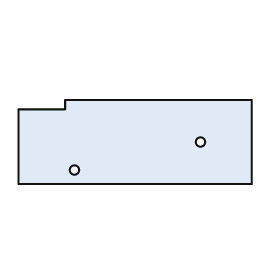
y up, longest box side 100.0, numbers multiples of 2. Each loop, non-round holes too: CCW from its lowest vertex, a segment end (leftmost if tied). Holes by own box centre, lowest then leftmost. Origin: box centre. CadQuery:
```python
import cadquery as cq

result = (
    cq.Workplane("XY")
    .moveTo(-50.0, -18.0)
    .lineTo(50.0, -18.0)
    .lineTo(50.0, 18.0)
    .lineTo(-30.0, 18.0)
    .lineTo(-30.0, 14.0)
    .lineTo(-50.0, 14.0)
    .close()
    .moveTo(-26.0, -12.0)
    .circle(2.0)
    .moveTo(28.0, 0.0)
    .circle(2.0)
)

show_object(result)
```